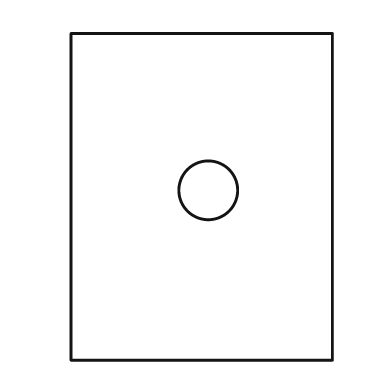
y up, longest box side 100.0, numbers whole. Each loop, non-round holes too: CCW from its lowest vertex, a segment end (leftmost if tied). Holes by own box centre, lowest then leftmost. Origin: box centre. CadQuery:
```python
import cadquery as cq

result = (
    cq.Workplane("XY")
    .moveTo(-40.0, -50.0)
    .lineTo(40.0, -50.0)
    .lineTo(40.0, 50.0)
    .lineTo(-40.0, 50.0)
    .close()
    .moveTo(2.0, 2.0)
    .circle(9.0)
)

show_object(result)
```